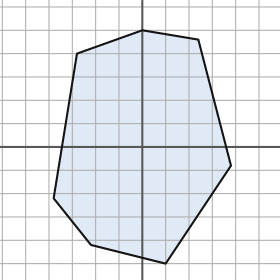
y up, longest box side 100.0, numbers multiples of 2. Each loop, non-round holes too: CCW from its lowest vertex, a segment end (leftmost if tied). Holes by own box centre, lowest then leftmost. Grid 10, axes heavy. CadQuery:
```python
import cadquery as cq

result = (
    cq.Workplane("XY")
    .moveTo(10.0, -50.0)
    .lineTo(38.0, -8.0)
    .lineTo(24.0, 46.0)
    .lineTo(0.0, 50.0)
    .lineTo(-28.0, 40.0)
    .lineTo(-38.0, -22.0)
    .lineTo(-22.0, -42.0)
    .close()
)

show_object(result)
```